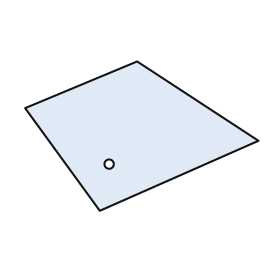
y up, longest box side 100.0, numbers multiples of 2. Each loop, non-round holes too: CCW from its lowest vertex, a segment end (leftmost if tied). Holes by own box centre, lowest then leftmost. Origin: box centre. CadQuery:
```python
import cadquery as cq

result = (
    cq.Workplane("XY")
    .moveTo(-18.0, -32.0)
    .lineTo(50.0, -2.0)
    .lineTo(-2.0, 32.0)
    .lineTo(-50.0, 12.0)
    .close()
    .moveTo(-14.0, -12.0)
    .circle(2.0)
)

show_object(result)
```